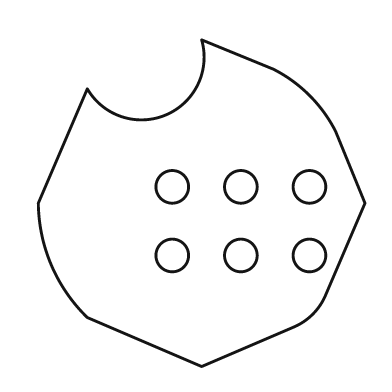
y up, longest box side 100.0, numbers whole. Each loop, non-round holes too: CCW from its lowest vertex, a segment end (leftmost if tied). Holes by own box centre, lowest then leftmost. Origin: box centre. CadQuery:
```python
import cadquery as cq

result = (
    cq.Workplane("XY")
    .moveTo(0.0, -50.0)
    .lineTo(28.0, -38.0)
    .threePointArc((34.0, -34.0), (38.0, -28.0))
    .lineTo(50.0, 0.0)
    .lineTo(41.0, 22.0)
    .threePointArc((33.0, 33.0), (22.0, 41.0))
    .lineTo(0.0, 50.0)
    .threePointArc((-11.0, 27.0), (-35.0, 35.0))
    .lineTo(-50.0, 0.0)
    .threePointArc((-46.0, -19.0), (-35.0, -35.0))
    .close()
    .moveTo(-9.0, -16.0)
    .circle(5.0)
    .moveTo(12.0, -16.0)
    .circle(5.0)
    .moveTo(33.0, -16.0)
    .circle(5.0)
    .moveTo(-9.0, 5.0)
    .circle(5.0)
    .moveTo(12.0, 5.0)
    .circle(5.0)
    .moveTo(33.0, 5.0)
    .circle(5.0)
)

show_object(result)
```